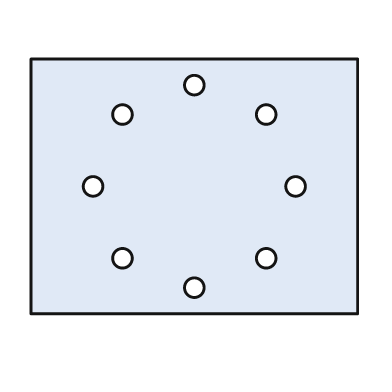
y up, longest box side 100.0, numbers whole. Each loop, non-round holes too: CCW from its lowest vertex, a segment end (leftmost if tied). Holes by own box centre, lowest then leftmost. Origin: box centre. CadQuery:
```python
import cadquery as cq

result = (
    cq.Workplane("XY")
    .moveTo(-50.0, -39.0)
    .lineTo(50.0, -39.0)
    .lineTo(50.0, 39.0)
    .lineTo(-50.0, 39.0)
    .close()
    .moveTo(0.0, -31.0)
    .circle(3.0)
    .moveTo(-22.0, -22.0)
    .circle(3.0)
    .moveTo(22.0, -22.0)
    .circle(3.0)
    .moveTo(-31.0, 0.0)
    .circle(3.0)
    .moveTo(31.0, 0.0)
    .circle(3.0)
    .moveTo(-22.0, 22.0)
    .circle(3.0)
    .moveTo(22.0, 22.0)
    .circle(3.0)
    .moveTo(0.0, 31.0)
    .circle(3.0)
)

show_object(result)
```